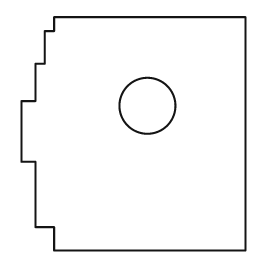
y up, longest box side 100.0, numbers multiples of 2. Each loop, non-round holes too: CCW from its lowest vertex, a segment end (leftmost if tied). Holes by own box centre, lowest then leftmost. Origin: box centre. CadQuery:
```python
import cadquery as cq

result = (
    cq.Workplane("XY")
    .moveTo(-34.0, -50.0)
    .lineTo(48.0, -50.0)
    .lineTo(48.0, 50.0)
    .lineTo(-34.0, 50.0)
    .lineTo(-34.0, 44.0)
    .lineTo(-38.0, 44.0)
    .lineTo(-38.0, 30.0)
    .lineTo(-42.0, 30.0)
    .lineTo(-42.0, 14.0)
    .lineTo(-48.0, 14.0)
    .lineTo(-48.0, -12.0)
    .lineTo(-42.0, -12.0)
    .lineTo(-42.0, -40.0)
    .lineTo(-34.0, -40.0)
    .close()
    .moveTo(6.0, 12.0)
    .circle(12.0)
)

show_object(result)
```